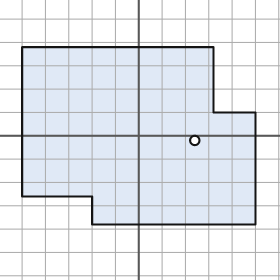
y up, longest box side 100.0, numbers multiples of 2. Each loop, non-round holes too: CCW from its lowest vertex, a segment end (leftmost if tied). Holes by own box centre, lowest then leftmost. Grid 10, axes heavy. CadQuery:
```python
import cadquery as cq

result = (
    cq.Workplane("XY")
    .moveTo(-20.0, -38.0)
    .lineTo(50.0, -38.0)
    .lineTo(50.0, 10.0)
    .lineTo(32.0, 10.0)
    .lineTo(32.0, 38.0)
    .lineTo(-50.0, 38.0)
    .lineTo(-50.0, -26.0)
    .lineTo(-20.0, -26.0)
    .close()
    .moveTo(24.0, -2.0)
    .circle(2.0)
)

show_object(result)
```